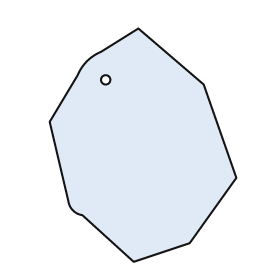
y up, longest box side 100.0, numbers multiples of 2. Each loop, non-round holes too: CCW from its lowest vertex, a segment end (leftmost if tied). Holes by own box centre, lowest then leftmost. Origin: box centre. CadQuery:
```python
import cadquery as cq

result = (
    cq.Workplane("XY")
    .moveTo(-4.0, -50.0)
    .lineTo(20.0, -42.0)
    .lineTo(40.0, -14.0)
    .lineTo(26.0, 26.0)
    .lineTo(-2.0, 50.0)
    .lineTo(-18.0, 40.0)
    .threePointArc((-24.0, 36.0), (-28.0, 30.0))
    .lineTo(-40.0, 10.0)
    .lineTo(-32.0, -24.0)
    .threePointArc((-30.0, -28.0), (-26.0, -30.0))
    .close()
    .moveTo(-16.0, 28.0)
    .circle(2.0)
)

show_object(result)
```